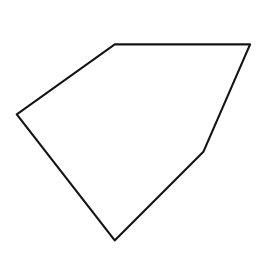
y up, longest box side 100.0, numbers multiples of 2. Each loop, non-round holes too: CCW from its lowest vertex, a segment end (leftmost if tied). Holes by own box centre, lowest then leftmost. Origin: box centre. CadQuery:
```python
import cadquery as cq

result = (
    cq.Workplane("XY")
    .moveTo(-8.0, -42.0)
    .lineTo(30.0, -4.0)
    .lineTo(50.0, 42.0)
    .lineTo(-8.0, 42.0)
    .lineTo(-50.0, 12.0)
    .close()
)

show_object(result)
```